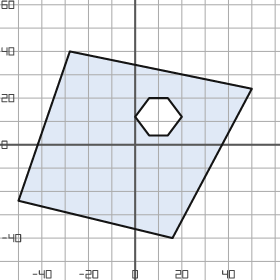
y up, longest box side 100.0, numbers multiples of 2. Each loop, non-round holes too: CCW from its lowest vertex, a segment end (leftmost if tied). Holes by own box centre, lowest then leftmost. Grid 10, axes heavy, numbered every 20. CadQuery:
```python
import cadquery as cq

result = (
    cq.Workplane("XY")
    .moveTo(16.0, -40.0)
    .lineTo(50.0, 24.0)
    .lineTo(-28.0, 40.0)
    .lineTo(-50.0, -24.0)
    .close()
    .moveTo(6.0, 4.0)
    .lineTo(14.0, 4.0)
    .lineTo(20.0, 12.0)
    .lineTo(14.0, 20.0)
    .lineTo(6.0, 20.0)
    .lineTo(0.0, 12.0)
    .close()
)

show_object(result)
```